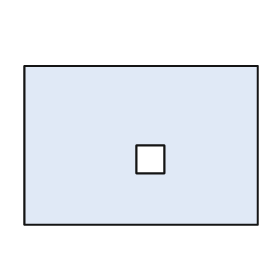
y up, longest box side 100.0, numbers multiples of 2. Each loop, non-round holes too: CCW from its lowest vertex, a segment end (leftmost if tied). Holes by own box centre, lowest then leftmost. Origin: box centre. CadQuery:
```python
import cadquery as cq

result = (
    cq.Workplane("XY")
    .moveTo(-50.0, -34.0)
    .lineTo(50.0, -34.0)
    .lineTo(50.0, 34.0)
    .lineTo(-50.0, 34.0)
    .close()
    .moveTo(-2.0, -12.0)
    .lineTo(10.0, -12.0)
    .lineTo(10.0, 0.0)
    .lineTo(-2.0, 0.0)
    .close()
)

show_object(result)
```